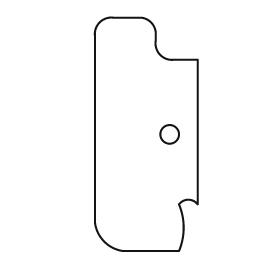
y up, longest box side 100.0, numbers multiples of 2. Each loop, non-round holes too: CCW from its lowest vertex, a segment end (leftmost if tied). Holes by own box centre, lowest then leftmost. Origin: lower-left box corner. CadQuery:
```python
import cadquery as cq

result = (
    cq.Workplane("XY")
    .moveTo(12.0, 0.0)
    .lineTo(36.0, 0.0)
    .threePointArc((38.0, 10.0), (36.0, 20.0))
    .threePointArc((40.0, 22.0), (44.0, 20.0))
    .lineTo(44.0, 82.0)
    .lineTo(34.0, 82.0)
    .threePointArc((28.0, 84.0), (26.0, 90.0))
    .lineTo(26.0, 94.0)
    .threePointArc((24.0, 98.0), (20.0, 100.0))
    .lineTo(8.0, 100.0)
    .threePointArc((2.0, 98.0), (0.0, 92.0))
    .lineTo(0.0, 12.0)
    .threePointArc((4.0, 4.0), (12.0, 0.0))
    .close()
    .moveTo(32.0, 50.0)
    .circle(4.0)
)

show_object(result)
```